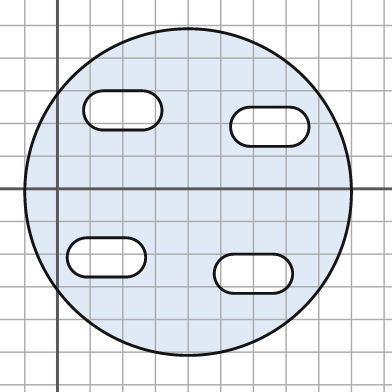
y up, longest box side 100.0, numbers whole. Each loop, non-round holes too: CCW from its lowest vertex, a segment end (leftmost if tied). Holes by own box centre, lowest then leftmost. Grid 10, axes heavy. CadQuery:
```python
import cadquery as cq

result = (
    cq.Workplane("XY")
    .moveTo(40.0, -1.0)
    .circle(50.0)
    .moveTo(54.0, -32.0)
    .lineTo(66.0, -32.0)
    .threePointArc((72.0, -26.0), (66.0, -20.0))
    .lineTo(54.0, -20.0)
    .threePointArc((48.0, -26.0), (54.0, -32.0))
    .close()
    .moveTo(9.0, -27.0)
    .lineTo(21.0, -27.0)
    .threePointArc((27.0, -21.0), (21.0, -15.0))
    .lineTo(9.0, -15.0)
    .threePointArc((3.0, -21.0), (9.0, -27.0))
    .close()
    .moveTo(59.0, 13.0)
    .lineTo(71.0, 13.0)
    .threePointArc((77.0, 19.0), (71.0, 25.0))
    .lineTo(59.0, 25.0)
    .threePointArc((53.0, 19.0), (59.0, 13.0))
    .close()
    .moveTo(14.0, 18.0)
    .lineTo(26.0, 18.0)
    .threePointArc((32.0, 24.0), (26.0, 30.0))
    .lineTo(14.0, 30.0)
    .threePointArc((8.0, 24.0), (14.0, 18.0))
    .close()
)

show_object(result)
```